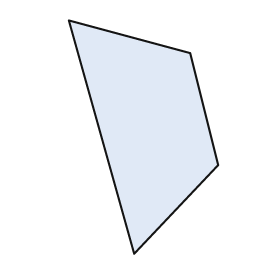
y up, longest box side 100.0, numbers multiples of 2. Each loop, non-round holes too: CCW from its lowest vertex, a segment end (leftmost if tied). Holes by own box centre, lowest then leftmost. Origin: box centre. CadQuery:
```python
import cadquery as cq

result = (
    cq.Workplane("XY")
    .moveTo(-4.0, -50.0)
    .lineTo(32.0, -12.0)
    .lineTo(20.0, 36.0)
    .lineTo(-32.0, 50.0)
    .close()
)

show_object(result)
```